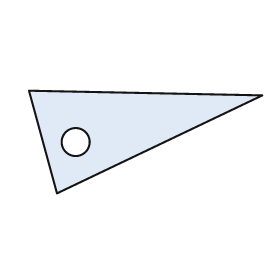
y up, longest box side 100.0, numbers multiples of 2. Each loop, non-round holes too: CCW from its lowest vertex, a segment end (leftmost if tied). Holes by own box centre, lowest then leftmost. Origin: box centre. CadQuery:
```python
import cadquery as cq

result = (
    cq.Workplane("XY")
    .moveTo(-38.0, -22.0)
    .lineTo(50.0, 20.0)
    .lineTo(-50.0, 22.0)
    .close()
    .moveTo(-30.0, 0.0)
    .circle(6.0)
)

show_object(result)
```